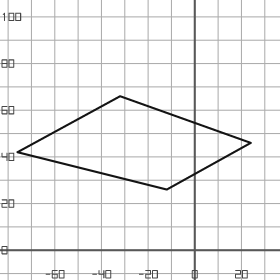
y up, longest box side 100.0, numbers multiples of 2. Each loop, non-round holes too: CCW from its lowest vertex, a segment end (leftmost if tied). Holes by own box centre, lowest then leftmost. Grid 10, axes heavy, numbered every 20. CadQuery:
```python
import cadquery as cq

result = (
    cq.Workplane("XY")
    .moveTo(-12.0, 26.0)
    .lineTo(24.0, 46.0)
    .lineTo(-32.0, 66.0)
    .lineTo(-76.0, 42.0)
    .close()
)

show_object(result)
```